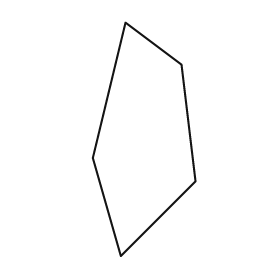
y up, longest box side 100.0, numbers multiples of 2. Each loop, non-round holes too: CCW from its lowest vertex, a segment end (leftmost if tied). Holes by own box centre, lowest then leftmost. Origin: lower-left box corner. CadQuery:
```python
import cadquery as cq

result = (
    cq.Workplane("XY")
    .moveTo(12.0, 0.0)
    .lineTo(44.0, 32.0)
    .lineTo(38.0, 82.0)
    .lineTo(14.0, 100.0)
    .lineTo(0.0, 42.0)
    .close()
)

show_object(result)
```